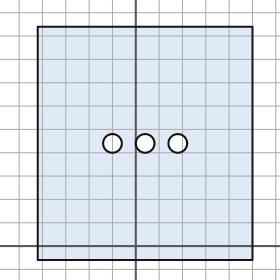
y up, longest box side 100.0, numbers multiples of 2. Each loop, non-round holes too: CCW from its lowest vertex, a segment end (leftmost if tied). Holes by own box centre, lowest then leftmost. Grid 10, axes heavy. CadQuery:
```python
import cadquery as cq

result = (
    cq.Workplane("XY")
    .moveTo(-42.0, -6.0)
    .lineTo(50.0, -6.0)
    .lineTo(50.0, 94.0)
    .lineTo(-42.0, 94.0)
    .close()
    .moveTo(-10.0, 44.0)
    .circle(4.0)
    .moveTo(4.0, 44.0)
    .circle(4.0)
    .moveTo(18.0, 44.0)
    .circle(4.0)
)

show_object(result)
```